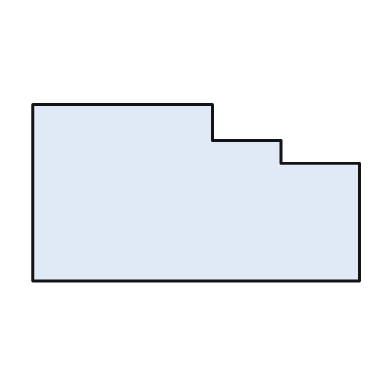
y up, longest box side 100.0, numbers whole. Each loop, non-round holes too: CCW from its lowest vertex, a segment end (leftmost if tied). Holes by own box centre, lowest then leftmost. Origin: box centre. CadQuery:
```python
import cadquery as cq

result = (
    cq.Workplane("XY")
    .moveTo(-50.0, -27.0)
    .lineTo(50.0, -27.0)
    .lineTo(50.0, 9.0)
    .lineTo(26.0, 9.0)
    .lineTo(26.0, 16.0)
    .lineTo(5.0, 16.0)
    .lineTo(5.0, 27.0)
    .lineTo(-50.0, 27.0)
    .close()
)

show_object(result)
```